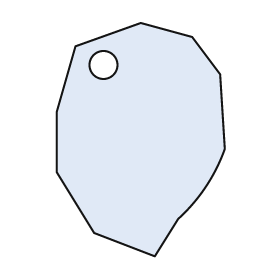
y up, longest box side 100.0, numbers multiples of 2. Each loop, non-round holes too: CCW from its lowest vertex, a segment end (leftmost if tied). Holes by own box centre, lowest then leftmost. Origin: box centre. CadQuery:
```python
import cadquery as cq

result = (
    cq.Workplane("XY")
    .moveTo(6.0, -50.0)
    .lineTo(16.0, -34.0)
    .threePointArc((28.0, -20.0), (36.0, -4.0))
    .lineTo(34.0, 28.0)
    .lineTo(22.0, 44.0)
    .lineTo(0.0, 50.0)
    .lineTo(-28.0, 40.0)
    .lineTo(-36.0, 12.0)
    .lineTo(-36.0, -14.0)
    .lineTo(-20.0, -40.0)
    .close()
    .moveTo(-16.0, 32.0)
    .circle(6.0)
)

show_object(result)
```